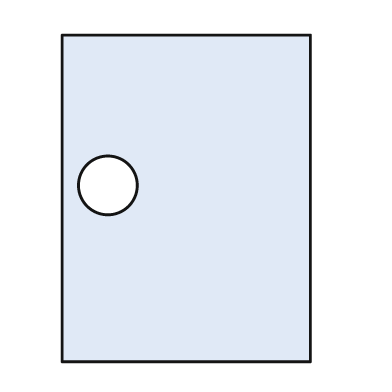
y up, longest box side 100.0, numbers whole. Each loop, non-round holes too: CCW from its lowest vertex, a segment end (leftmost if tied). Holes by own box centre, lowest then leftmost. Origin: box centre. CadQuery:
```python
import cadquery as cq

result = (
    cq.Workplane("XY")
    .moveTo(-38.0, -50.0)
    .lineTo(38.0, -50.0)
    .lineTo(38.0, 50.0)
    .lineTo(-38.0, 50.0)
    .close()
    .moveTo(-24.0, 4.0)
    .circle(9.0)
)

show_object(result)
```